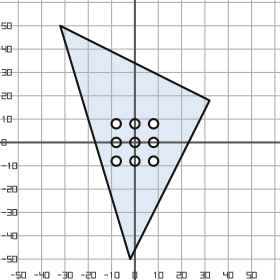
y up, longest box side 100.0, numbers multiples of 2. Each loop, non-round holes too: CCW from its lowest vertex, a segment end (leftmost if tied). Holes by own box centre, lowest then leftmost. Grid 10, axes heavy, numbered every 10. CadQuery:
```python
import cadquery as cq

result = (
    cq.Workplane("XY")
    .moveTo(-2.0, -50.0)
    .lineTo(32.0, 18.0)
    .lineTo(-32.0, 50.0)
    .close()
    .moveTo(-8.0, -8.0)
    .circle(2.0)
    .moveTo(0.0, -8.0)
    .circle(2.0)
    .moveTo(8.0, -8.0)
    .circle(2.0)
    .moveTo(-8.0, 0.0)
    .circle(2.0)
    .moveTo(0.0, 0.0)
    .circle(2.0)
    .moveTo(8.0, 0.0)
    .circle(2.0)
    .moveTo(-8.0, 8.0)
    .circle(2.0)
    .moveTo(0.0, 8.0)
    .circle(2.0)
    .moveTo(8.0, 8.0)
    .circle(2.0)
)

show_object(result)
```